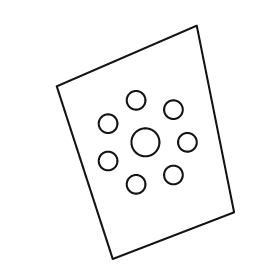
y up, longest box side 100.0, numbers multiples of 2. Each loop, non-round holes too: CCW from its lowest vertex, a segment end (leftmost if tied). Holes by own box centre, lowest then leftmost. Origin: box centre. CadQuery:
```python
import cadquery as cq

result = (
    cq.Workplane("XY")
    .moveTo(-14.0, -50.0)
    .lineTo(38.0, -30.0)
    .lineTo(22.0, 50.0)
    .lineTo(-38.0, 24.0)
    .close()
    .moveTo(-4.0, -18.0)
    .circle(4.0)
    .moveTo(12.0, -14.0)
    .circle(4.0)
    .moveTo(-16.0, -8.0)
    .circle(4.0)
    .moveTo(0.0, 0.0)
    .circle(6.0)
    .moveTo(18.0, 0.0)
    .circle(4.0)
    .moveTo(-16.0, 8.0)
    .circle(4.0)
    .moveTo(12.0, 14.0)
    .circle(4.0)
    .moveTo(-4.0, 18.0)
    .circle(4.0)
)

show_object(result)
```